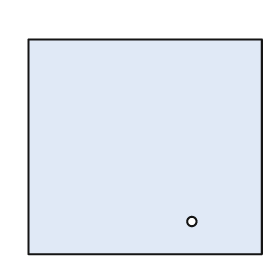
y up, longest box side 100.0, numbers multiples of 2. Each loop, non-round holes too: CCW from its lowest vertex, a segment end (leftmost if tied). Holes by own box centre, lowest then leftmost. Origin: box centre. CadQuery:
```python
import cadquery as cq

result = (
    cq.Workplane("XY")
    .moveTo(-50.0, -46.0)
    .lineTo(50.0, -46.0)
    .lineTo(50.0, 46.0)
    .lineTo(-50.0, 46.0)
    .close()
    .moveTo(20.0, -32.0)
    .circle(2.0)
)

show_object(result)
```